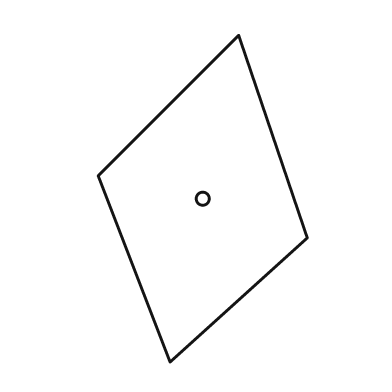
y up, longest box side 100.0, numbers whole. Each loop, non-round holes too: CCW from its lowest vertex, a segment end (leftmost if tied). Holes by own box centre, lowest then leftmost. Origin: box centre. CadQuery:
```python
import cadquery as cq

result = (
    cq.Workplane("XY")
    .moveTo(-10.0, -50.0)
    .lineTo(32.0, -12.0)
    .lineTo(11.0, 50.0)
    .lineTo(-32.0, 7.0)
    .close()
    .moveTo(0.0, 0.0)
    .circle(2.0)
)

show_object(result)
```